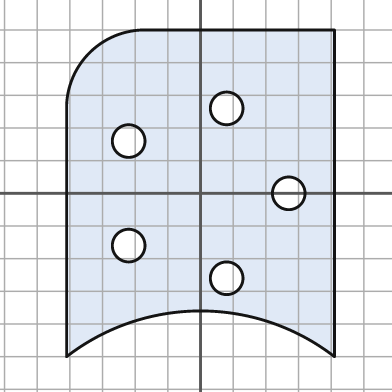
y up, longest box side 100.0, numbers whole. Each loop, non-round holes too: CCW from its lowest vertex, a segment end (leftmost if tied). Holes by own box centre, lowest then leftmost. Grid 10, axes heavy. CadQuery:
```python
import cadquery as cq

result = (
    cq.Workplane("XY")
    .moveTo(-41.0, -50.0)
    .threePointArc((0.0, -36.0), (41.0, -50.0))
    .lineTo(41.0, 50.0)
    .lineTo(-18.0, 50.0)
    .threePointArc((-34.0, 43.0), (-41.0, 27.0))
    .close()
    .moveTo(8.0, -26.0)
    .circle(5.0)
    .moveTo(-22.0, -16.0)
    .circle(5.0)
    .moveTo(27.0, 0.0)
    .circle(5.0)
    .moveTo(-22.0, 16.0)
    .circle(5.0)
    .moveTo(8.0, 26.0)
    .circle(5.0)
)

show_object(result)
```